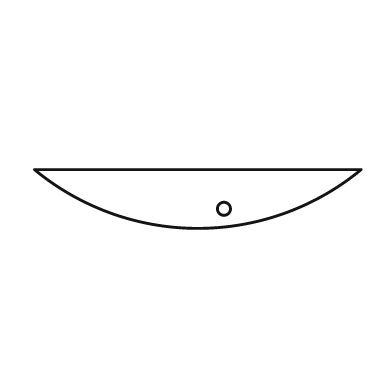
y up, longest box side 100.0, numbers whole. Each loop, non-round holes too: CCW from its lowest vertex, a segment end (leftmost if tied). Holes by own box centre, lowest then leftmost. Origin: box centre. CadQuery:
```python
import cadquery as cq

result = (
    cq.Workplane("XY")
    .moveTo(-50.0, 9.0)
    .threePointArc((0.0, -9.0), (50.0, 9.0))
    .close()
    .moveTo(8.0, -3.0)
    .circle(2.0)
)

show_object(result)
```